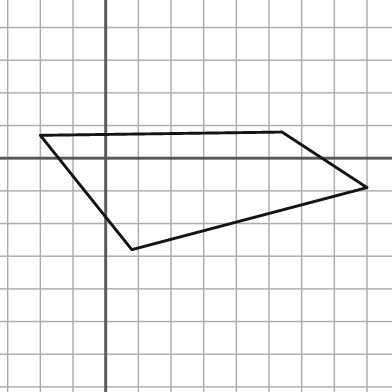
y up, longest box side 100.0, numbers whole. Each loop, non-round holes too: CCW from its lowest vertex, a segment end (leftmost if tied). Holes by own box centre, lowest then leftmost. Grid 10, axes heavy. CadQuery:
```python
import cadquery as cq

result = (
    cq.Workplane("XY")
    .moveTo(8.0, -28.0)
    .lineTo(80.0, -9.0)
    .lineTo(54.0, 8.0)
    .lineTo(-20.0, 7.0)
    .close()
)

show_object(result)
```